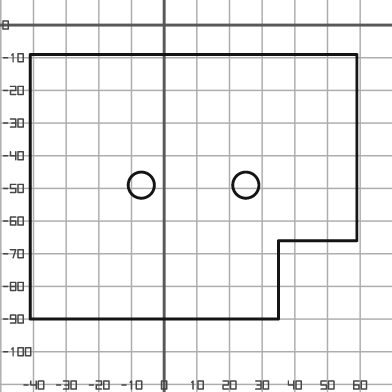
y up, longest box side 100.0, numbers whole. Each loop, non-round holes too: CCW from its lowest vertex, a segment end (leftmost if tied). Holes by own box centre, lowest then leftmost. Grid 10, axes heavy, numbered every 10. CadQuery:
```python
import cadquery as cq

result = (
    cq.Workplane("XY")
    .moveTo(-41.0, -90.0)
    .lineTo(35.0, -90.0)
    .lineTo(35.0, -66.0)
    .lineTo(59.0, -66.0)
    .lineTo(59.0, -9.0)
    .lineTo(-41.0, -9.0)
    .close()
    .moveTo(-7.0, -49.0)
    .circle(4.0)
    .moveTo(25.0, -49.0)
    .circle(4.0)
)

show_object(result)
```